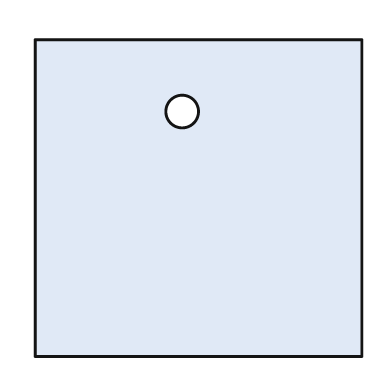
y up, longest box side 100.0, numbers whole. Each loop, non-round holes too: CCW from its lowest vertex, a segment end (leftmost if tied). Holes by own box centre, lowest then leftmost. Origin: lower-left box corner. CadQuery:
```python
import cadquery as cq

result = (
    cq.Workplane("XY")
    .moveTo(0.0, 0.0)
    .lineTo(100.0, 0.0)
    .lineTo(100.0, 97.0)
    .lineTo(0.0, 97.0)
    .close()
    .moveTo(45.0, 75.0)
    .circle(5.0)
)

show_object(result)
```